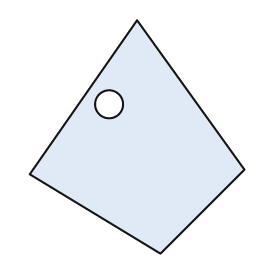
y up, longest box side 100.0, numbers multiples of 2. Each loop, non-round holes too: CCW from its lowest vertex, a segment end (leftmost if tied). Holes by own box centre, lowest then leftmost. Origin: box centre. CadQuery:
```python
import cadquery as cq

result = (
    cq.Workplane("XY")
    .moveTo(10.0, -50.0)
    .lineTo(46.0, -14.0)
    .lineTo(0.0, 50.0)
    .lineTo(-46.0, -16.0)
    .close()
    .moveTo(-12.0, 14.0)
    .circle(6.0)
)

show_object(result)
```